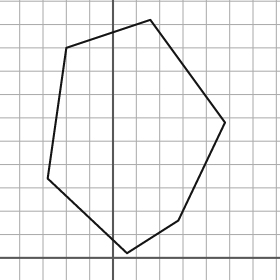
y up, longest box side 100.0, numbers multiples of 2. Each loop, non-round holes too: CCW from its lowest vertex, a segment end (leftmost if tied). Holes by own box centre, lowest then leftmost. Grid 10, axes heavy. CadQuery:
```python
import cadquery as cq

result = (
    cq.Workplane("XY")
    .moveTo(6.0, 2.0)
    .lineTo(28.0, 16.0)
    .lineTo(48.0, 58.0)
    .lineTo(16.0, 102.0)
    .lineTo(-20.0, 90.0)
    .lineTo(-28.0, 34.0)
    .close()
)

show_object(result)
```